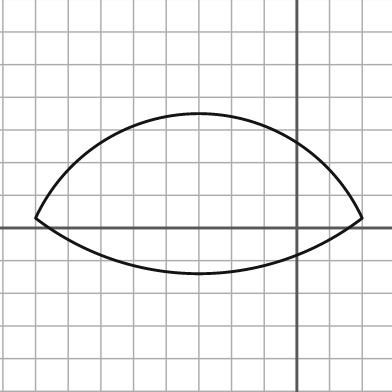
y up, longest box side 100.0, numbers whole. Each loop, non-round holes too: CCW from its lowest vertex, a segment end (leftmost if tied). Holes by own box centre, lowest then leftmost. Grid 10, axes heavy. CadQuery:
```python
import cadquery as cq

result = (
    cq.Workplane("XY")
    .moveTo(-80.0, 3.0)
    .threePointArc((-30.0, -14.0), (20.0, 3.0))
    .threePointArc((-30.0, 35.0), (-80.0, 3.0))
    .close()
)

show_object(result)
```